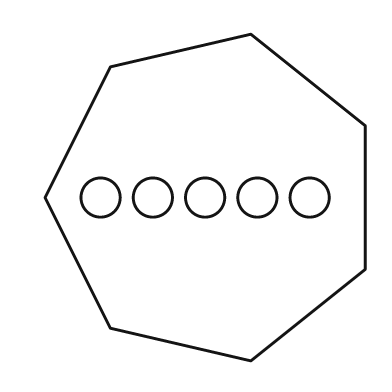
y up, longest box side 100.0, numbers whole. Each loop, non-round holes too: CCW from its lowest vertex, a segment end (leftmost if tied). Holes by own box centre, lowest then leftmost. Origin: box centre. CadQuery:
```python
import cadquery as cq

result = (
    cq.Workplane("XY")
    .moveTo(14.0, -50.0)
    .lineTo(49.0, -22.0)
    .lineTo(49.0, 22.0)
    .lineTo(14.0, 50.0)
    .lineTo(-29.0, 40.0)
    .lineTo(-49.0, 0.0)
    .lineTo(-29.0, -40.0)
    .close()
    .moveTo(-32.0, 0.0)
    .circle(6.0)
    .moveTo(-16.0, 0.0)
    .circle(6.0)
    .moveTo(0.0, 0.0)
    .circle(6.0)
    .moveTo(16.0, 0.0)
    .circle(6.0)
    .moveTo(32.0, 0.0)
    .circle(6.0)
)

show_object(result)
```